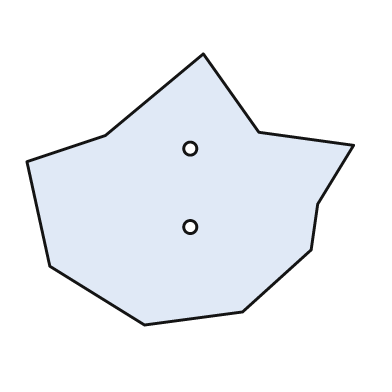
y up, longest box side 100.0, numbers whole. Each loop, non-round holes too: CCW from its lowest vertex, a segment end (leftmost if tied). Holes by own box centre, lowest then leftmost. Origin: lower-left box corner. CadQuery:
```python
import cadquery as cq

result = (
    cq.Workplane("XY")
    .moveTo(36.0, 0.0)
    .lineTo(66.0, 4.0)
    .lineTo(87.0, 23.0)
    .lineTo(89.0, 37.0)
    .lineTo(100.0, 55.0)
    .lineTo(71.0, 59.0)
    .lineTo(54.0, 83.0)
    .lineTo(24.0, 58.0)
    .lineTo(0.0, 50.0)
    .lineTo(7.0, 18.0)
    .close()
    .moveTo(50.0, 30.0)
    .circle(2.0)
    .moveTo(50.0, 54.0)
    .circle(2.0)
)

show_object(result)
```